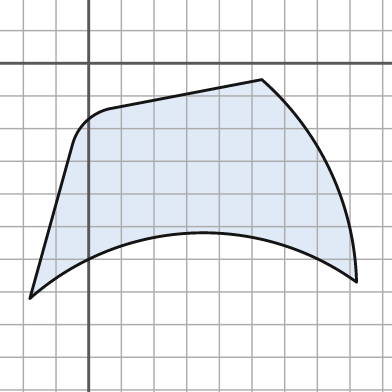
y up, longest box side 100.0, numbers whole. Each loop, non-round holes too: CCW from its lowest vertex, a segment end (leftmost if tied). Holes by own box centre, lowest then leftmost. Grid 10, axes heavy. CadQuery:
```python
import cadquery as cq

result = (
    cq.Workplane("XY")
    .moveTo(-18.0, -72.0)
    .threePointArc((31.0, -52.0), (82.0, -67.0))
    .threePointArc((74.0, -33.0), (53.0, -5.0))
    .lineTo(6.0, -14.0)
    .threePointArc((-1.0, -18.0), (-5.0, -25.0))
    .close()
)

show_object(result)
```